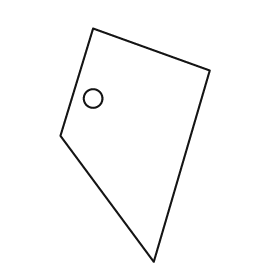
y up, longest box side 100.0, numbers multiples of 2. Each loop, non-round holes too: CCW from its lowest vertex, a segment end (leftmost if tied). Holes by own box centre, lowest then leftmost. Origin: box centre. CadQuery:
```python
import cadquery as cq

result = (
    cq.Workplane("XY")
    .moveTo(8.0, -50.0)
    .lineTo(32.0, 32.0)
    .lineTo(-18.0, 50.0)
    .lineTo(-32.0, 4.0)
    .close()
    .moveTo(-18.0, 20.0)
    .circle(4.0)
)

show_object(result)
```